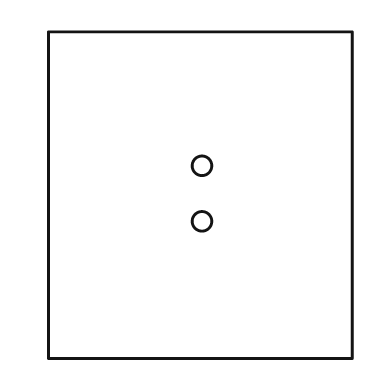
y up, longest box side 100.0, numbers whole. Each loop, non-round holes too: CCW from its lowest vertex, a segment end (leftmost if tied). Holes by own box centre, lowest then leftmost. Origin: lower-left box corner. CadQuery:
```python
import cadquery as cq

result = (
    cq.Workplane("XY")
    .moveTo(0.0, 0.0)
    .lineTo(93.0, 0.0)
    .lineTo(93.0, 100.0)
    .lineTo(0.0, 100.0)
    .close()
    .moveTo(47.0, 42.0)
    .circle(3.0)
    .moveTo(47.0, 59.0)
    .circle(3.0)
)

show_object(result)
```